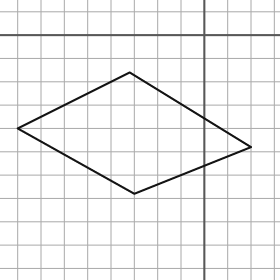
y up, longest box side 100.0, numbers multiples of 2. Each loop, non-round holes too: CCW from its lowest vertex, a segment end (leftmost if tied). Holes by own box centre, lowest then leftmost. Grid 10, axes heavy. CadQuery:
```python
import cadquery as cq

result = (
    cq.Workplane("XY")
    .moveTo(-30.0, -68.0)
    .lineTo(20.0, -48.0)
    .lineTo(-32.0, -16.0)
    .lineTo(-80.0, -40.0)
    .close()
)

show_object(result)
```